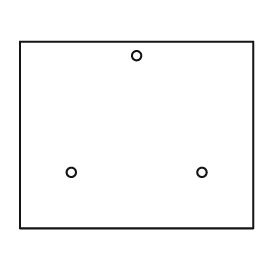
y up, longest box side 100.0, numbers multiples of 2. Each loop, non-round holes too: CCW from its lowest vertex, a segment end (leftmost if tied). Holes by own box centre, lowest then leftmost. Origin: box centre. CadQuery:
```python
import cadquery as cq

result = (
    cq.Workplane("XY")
    .moveTo(-50.0, -40.0)
    .lineTo(50.0, -40.0)
    .lineTo(50.0, 40.0)
    .lineTo(-50.0, 40.0)
    .close()
    .moveTo(-28.0, -16.0)
    .circle(2.0)
    .moveTo(28.0, -16.0)
    .circle(2.0)
    .moveTo(0.0, 34.0)
    .circle(2.0)
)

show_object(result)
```